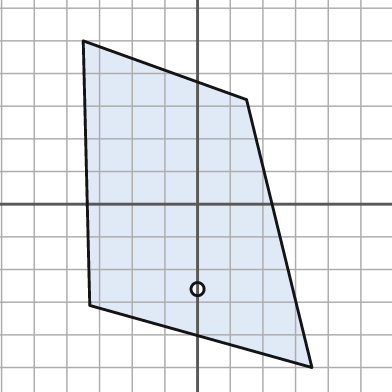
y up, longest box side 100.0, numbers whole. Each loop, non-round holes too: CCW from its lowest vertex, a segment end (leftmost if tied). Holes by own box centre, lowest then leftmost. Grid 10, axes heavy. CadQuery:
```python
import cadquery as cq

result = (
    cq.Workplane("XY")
    .moveTo(35.0, -50.0)
    .lineTo(15.0, 32.0)
    .lineTo(-35.0, 50.0)
    .lineTo(-33.0, -31.0)
    .close()
    .moveTo(0.0, -26.0)
    .circle(2.0)
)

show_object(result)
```